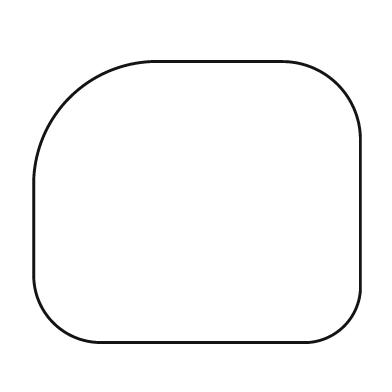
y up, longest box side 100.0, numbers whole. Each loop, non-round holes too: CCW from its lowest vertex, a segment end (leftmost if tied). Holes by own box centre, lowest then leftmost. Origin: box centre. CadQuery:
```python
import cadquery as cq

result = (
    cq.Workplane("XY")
    .moveTo(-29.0, -43.0)
    .lineTo(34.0, -43.0)
    .threePointArc((45.0, -38.0), (50.0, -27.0))
    .lineTo(50.0, 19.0)
    .threePointArc((43.0, 36.0), (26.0, 43.0))
    .lineTo(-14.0, 43.0)
    .threePointArc((-39.0, 32.0), (-50.0, 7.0))
    .lineTo(-50.0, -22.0)
    .threePointArc((-44.0, -37.0), (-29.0, -43.0))
    .close()
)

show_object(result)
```